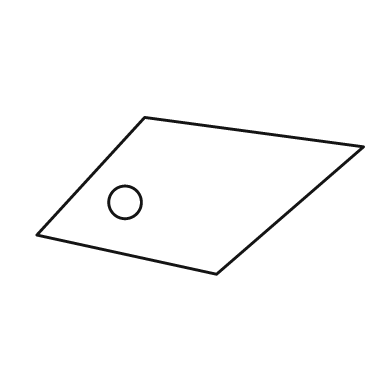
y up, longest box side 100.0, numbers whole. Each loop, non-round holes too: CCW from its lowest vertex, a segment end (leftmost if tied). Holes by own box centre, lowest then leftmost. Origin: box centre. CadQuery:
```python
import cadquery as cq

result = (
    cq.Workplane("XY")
    .moveTo(5.0, -24.0)
    .lineTo(50.0, 15.0)
    .lineTo(-17.0, 24.0)
    .lineTo(-50.0, -12.0)
    .close()
    .moveTo(-23.0, -2.0)
    .circle(5.0)
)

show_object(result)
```